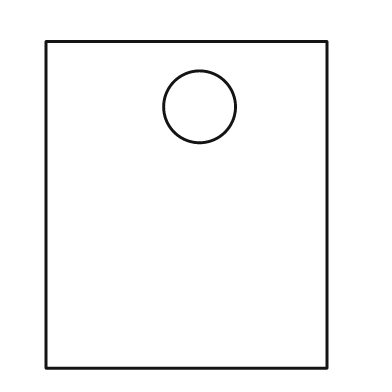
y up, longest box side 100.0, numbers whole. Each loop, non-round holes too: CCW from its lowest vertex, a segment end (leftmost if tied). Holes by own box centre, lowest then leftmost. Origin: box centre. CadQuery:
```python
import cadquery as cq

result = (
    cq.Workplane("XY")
    .moveTo(-43.0, -50.0)
    .lineTo(43.0, -50.0)
    .lineTo(43.0, 50.0)
    .lineTo(-43.0, 50.0)
    .close()
    .moveTo(4.0, 30.0)
    .circle(11.0)
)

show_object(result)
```